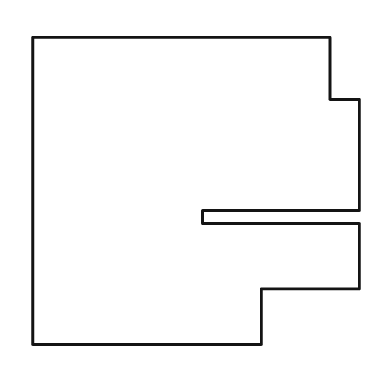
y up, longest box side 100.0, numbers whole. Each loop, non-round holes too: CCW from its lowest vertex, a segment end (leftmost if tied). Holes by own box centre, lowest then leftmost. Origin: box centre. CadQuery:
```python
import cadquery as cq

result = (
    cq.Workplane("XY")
    .moveTo(-50.0, -47.0)
    .lineTo(20.0, -47.0)
    .lineTo(20.0, -30.0)
    .lineTo(50.0, -30.0)
    .lineTo(50.0, -10.0)
    .lineTo(2.0, -10.0)
    .lineTo(2.0, -6.0)
    .lineTo(50.0, -6.0)
    .lineTo(50.0, 28.0)
    .lineTo(41.0, 28.0)
    .lineTo(41.0, 47.0)
    .lineTo(-50.0, 47.0)
    .close()
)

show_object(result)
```